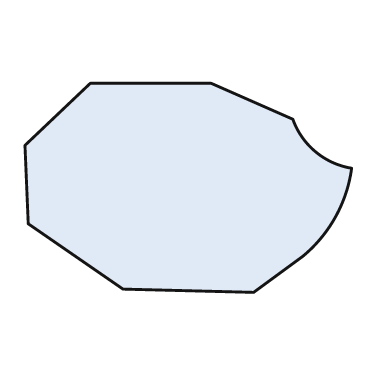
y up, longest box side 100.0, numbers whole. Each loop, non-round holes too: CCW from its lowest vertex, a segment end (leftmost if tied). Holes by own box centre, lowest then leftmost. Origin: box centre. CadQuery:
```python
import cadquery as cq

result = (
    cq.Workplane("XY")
    .moveTo(20.0, -32.0)
    .lineTo(35.0, -21.0)
    .threePointArc((45.0, -9.0), (50.0, 6.0))
    .threePointArc((39.0, 11.0), (32.0, 21.0))
    .lineTo(7.0, 32.0)
    .lineTo(-30.0, 32.0)
    .lineTo(-50.0, 13.0)
    .lineTo(-49.0, -11.0)
    .lineTo(-20.0, -31.0)
    .close()
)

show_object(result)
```